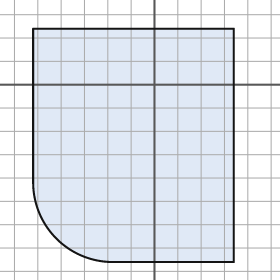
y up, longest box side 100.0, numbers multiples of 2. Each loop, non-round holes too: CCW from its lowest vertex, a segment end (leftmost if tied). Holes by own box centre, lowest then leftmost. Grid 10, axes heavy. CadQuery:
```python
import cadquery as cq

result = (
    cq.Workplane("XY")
    .moveTo(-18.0, -76.0)
    .lineTo(34.0, -76.0)
    .lineTo(34.0, 24.0)
    .lineTo(-52.0, 24.0)
    .lineTo(-52.0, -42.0)
    .threePointArc((-42.0, -66.0), (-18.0, -76.0))
    .close()
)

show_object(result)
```